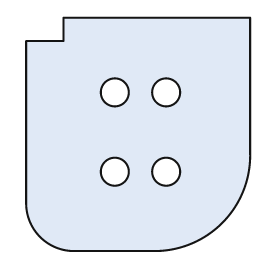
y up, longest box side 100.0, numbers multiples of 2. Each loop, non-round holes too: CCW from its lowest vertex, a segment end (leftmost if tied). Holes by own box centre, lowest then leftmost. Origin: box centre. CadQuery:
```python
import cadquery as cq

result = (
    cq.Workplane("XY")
    .moveTo(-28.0, -50.0)
    .lineTo(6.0, -50.0)
    .threePointArc((36.0, -38.0), (48.0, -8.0))
    .lineTo(48.0, 50.0)
    .lineTo(-32.0, 50.0)
    .lineTo(-32.0, 40.0)
    .lineTo(-48.0, 40.0)
    .lineTo(-48.0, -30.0)
    .threePointArc((-42.0, -44.0), (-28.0, -50.0))
    .close()
    .moveTo(-10.0, -16.0)
    .circle(6.0)
    .moveTo(12.0, -16.0)
    .circle(6.0)
    .moveTo(-10.0, 18.0)
    .circle(6.0)
    .moveTo(12.0, 18.0)
    .circle(6.0)
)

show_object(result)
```